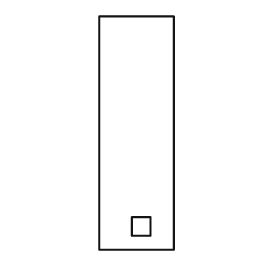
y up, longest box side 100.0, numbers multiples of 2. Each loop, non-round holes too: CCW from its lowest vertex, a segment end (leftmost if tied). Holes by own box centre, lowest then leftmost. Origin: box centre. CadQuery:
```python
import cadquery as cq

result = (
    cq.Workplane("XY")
    .moveTo(-16.0, -50.0)
    .lineTo(16.0, -50.0)
    .lineTo(16.0, 50.0)
    .lineTo(-16.0, 50.0)
    .close()
    .moveTo(-2.0, -44.0)
    .lineTo(6.0, -44.0)
    .lineTo(6.0, -36.0)
    .lineTo(-2.0, -36.0)
    .close()
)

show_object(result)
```